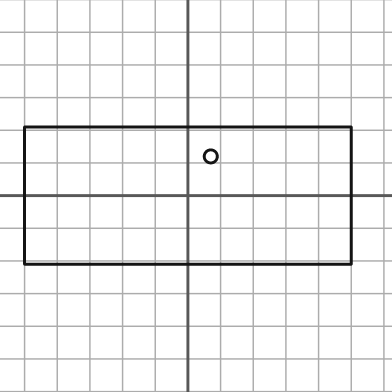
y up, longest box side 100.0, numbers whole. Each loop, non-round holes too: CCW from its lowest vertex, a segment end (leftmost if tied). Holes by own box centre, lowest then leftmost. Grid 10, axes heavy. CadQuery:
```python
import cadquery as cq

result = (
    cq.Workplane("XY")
    .moveTo(-50.0, -21.0)
    .lineTo(50.0, -21.0)
    .lineTo(50.0, 21.0)
    .lineTo(-50.0, 21.0)
    .close()
    .moveTo(7.0, 12.0)
    .circle(2.0)
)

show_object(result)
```